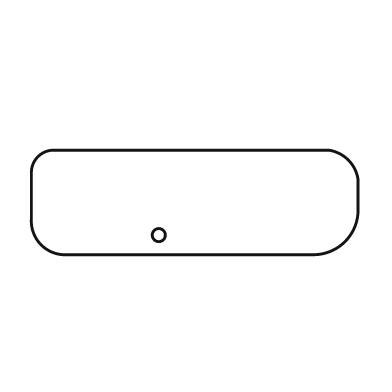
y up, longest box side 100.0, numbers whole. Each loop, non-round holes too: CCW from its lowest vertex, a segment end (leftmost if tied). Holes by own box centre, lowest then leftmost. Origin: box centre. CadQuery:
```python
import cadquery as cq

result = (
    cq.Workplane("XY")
    .moveTo(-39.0, -16.0)
    .lineTo(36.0, -16.0)
    .threePointArc((46.0, -12.0), (50.0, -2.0))
    .lineTo(50.0, 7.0)
    .threePointArc((47.0, 13.0), (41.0, 16.0))
    .lineTo(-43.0, 16.0)
    .threePointArc((-48.0, 14.0), (-50.0, 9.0))
    .lineTo(-50.0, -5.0)
    .threePointArc((-47.0, -13.0), (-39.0, -16.0))
    .close()
    .moveTo(-11.0, -10.0)
    .circle(2.0)
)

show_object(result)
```